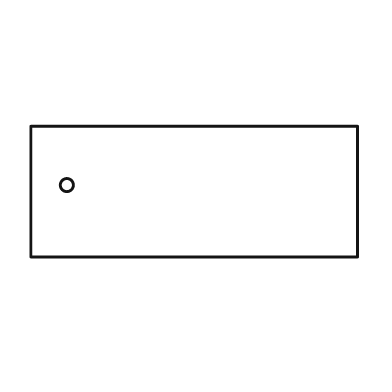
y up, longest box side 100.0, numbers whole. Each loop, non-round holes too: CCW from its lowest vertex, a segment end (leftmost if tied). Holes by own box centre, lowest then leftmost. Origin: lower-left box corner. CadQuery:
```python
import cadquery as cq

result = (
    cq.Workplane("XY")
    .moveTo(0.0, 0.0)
    .lineTo(100.0, 0.0)
    .lineTo(100.0, 40.0)
    .lineTo(0.0, 40.0)
    .close()
    .moveTo(11.0, 22.0)
    .circle(2.0)
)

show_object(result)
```